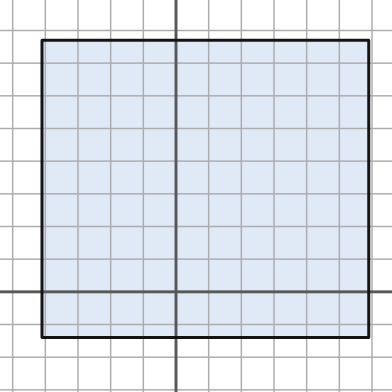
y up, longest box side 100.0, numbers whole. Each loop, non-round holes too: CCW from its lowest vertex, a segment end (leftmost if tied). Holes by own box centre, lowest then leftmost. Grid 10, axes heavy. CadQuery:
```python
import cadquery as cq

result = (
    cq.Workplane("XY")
    .moveTo(-41.0, -14.0)
    .lineTo(59.0, -14.0)
    .lineTo(59.0, 77.0)
    .lineTo(-41.0, 77.0)
    .close()
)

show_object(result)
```